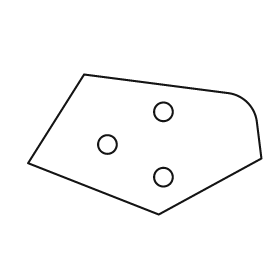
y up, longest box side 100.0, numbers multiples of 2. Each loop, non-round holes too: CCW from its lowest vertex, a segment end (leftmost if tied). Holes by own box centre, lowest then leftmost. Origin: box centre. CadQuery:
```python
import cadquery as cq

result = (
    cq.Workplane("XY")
    .moveTo(6.0, -30.0)
    .lineTo(50.0, -6.0)
    .lineTo(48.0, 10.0)
    .threePointArc((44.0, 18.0), (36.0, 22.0))
    .lineTo(-26.0, 30.0)
    .lineTo(-50.0, -8.0)
    .close()
    .moveTo(8.0, -14.0)
    .circle(4.0)
    .moveTo(-16.0, 0.0)
    .circle(4.0)
    .moveTo(8.0, 14.0)
    .circle(4.0)
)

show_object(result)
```